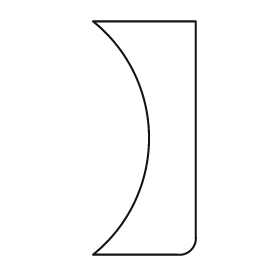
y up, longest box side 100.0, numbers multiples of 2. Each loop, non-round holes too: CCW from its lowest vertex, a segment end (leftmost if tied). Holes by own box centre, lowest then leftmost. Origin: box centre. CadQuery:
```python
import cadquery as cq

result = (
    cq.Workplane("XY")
    .moveTo(-22.0, -50.0)
    .lineTo(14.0, -50.0)
    .threePointArc((20.0, -48.0), (22.0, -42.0))
    .lineTo(22.0, 50.0)
    .lineTo(-22.0, 50.0)
    .threePointArc((2.0, 0.0), (-22.0, -50.0))
    .close()
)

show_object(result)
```